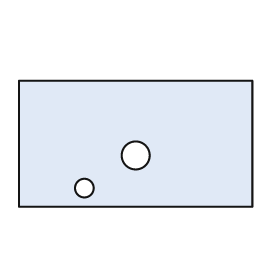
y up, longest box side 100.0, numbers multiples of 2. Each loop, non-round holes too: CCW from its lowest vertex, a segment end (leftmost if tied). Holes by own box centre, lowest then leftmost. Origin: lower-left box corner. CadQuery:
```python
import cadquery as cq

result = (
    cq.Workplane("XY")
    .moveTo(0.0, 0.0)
    .lineTo(100.0, 0.0)
    .lineTo(100.0, 54.0)
    .lineTo(0.0, 54.0)
    .close()
    .moveTo(28.0, 8.0)
    .circle(4.0)
    .moveTo(50.0, 22.0)
    .circle(6.0)
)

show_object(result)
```